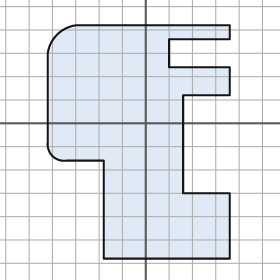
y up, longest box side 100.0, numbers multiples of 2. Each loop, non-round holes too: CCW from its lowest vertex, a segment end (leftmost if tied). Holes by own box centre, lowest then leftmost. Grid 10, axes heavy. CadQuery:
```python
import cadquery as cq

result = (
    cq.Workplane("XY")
    .moveTo(-18.0, -58.0)
    .lineTo(36.0, -58.0)
    .lineTo(36.0, -30.0)
    .lineTo(16.0, -30.0)
    .lineTo(16.0, 12.0)
    .lineTo(36.0, 12.0)
    .lineTo(36.0, 24.0)
    .lineTo(10.0, 24.0)
    .lineTo(10.0, 36.0)
    .lineTo(36.0, 36.0)
    .lineTo(36.0, 42.0)
    .lineTo(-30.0, 42.0)
    .threePointArc((-38.0, 38.0), (-42.0, 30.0))
    .lineTo(-42.0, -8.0)
    .threePointArc((-40.0, -14.0), (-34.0, -16.0))
    .lineTo(-18.0, -16.0)
    .close()
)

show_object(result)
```